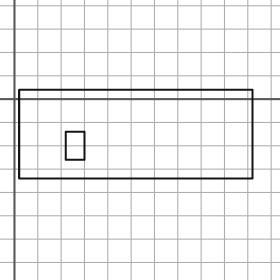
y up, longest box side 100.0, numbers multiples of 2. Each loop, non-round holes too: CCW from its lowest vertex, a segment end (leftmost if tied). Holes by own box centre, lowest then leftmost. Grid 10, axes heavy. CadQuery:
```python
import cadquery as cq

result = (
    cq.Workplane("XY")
    .moveTo(2.0, -34.0)
    .lineTo(102.0, -34.0)
    .lineTo(102.0, 4.0)
    .lineTo(2.0, 4.0)
    .close()
    .moveTo(22.0, -26.0)
    .lineTo(30.0, -26.0)
    .lineTo(30.0, -14.0)
    .lineTo(22.0, -14.0)
    .close()
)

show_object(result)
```